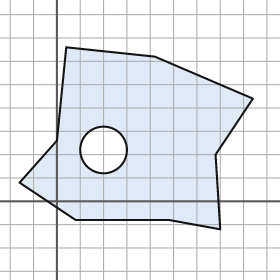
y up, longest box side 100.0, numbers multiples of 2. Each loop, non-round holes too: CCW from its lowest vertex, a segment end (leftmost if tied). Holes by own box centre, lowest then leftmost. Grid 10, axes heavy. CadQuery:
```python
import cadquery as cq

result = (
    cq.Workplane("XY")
    .moveTo(70.0, -12.0)
    .lineTo(68.0, 20.0)
    .lineTo(84.0, 44.0)
    .lineTo(42.0, 62.0)
    .lineTo(4.0, 66.0)
    .lineTo(0.0, 26.0)
    .lineTo(-16.0, 8.0)
    .lineTo(8.0, -8.0)
    .lineTo(48.0, -8.0)
    .close()
    .moveTo(20.0, 22.0)
    .circle(10.0)
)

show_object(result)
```